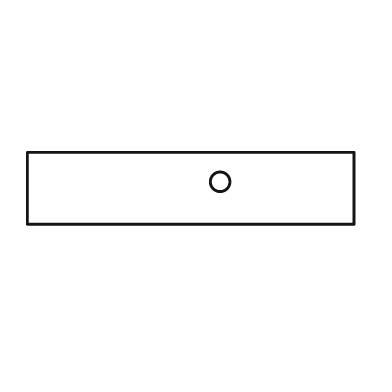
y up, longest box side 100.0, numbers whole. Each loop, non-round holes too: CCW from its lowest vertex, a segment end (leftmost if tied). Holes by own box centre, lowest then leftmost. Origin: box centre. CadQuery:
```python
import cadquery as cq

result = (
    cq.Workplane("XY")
    .moveTo(-50.0, -11.0)
    .lineTo(50.0, -11.0)
    .lineTo(50.0, 11.0)
    .lineTo(-50.0, 11.0)
    .close()
    .moveTo(9.0, 2.0)
    .circle(3.0)
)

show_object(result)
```